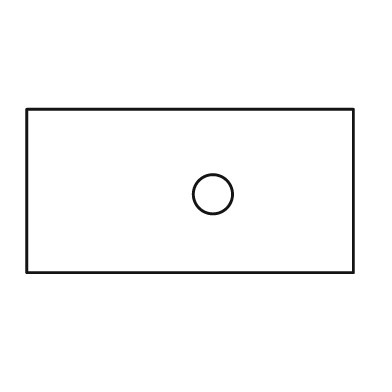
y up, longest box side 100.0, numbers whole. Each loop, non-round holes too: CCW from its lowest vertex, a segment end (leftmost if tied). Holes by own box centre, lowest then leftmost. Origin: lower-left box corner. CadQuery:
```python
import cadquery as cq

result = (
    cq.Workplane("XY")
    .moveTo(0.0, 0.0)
    .lineTo(100.0, 0.0)
    .lineTo(100.0, 50.0)
    .lineTo(0.0, 50.0)
    .close()
    .moveTo(57.0, 24.0)
    .circle(6.0)
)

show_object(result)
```